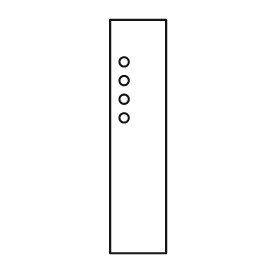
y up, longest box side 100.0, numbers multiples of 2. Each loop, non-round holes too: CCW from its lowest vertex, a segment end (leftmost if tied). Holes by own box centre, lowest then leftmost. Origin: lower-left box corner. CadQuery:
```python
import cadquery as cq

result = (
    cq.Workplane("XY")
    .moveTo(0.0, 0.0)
    .lineTo(24.0, 0.0)
    .lineTo(24.0, 100.0)
    .lineTo(0.0, 100.0)
    .close()
    .moveTo(6.0, 58.0)
    .circle(2.0)
    .moveTo(6.0, 66.0)
    .circle(2.0)
    .moveTo(6.0, 74.0)
    .circle(2.0)
    .moveTo(6.0, 82.0)
    .circle(2.0)
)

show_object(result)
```